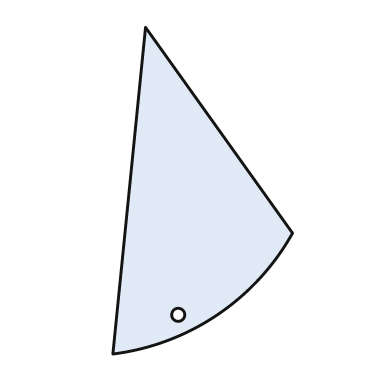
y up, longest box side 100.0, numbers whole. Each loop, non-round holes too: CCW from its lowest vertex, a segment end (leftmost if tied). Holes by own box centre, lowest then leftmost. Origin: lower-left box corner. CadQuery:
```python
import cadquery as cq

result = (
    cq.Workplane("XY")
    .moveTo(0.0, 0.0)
    .threePointArc((32.0, 12.0), (55.0, 37.0))
    .lineTo(10.0, 100.0)
    .close()
    .moveTo(20.0, 12.0)
    .circle(2.0)
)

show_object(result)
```